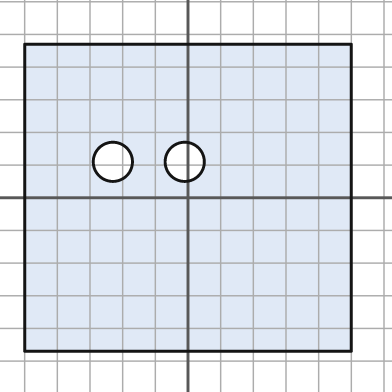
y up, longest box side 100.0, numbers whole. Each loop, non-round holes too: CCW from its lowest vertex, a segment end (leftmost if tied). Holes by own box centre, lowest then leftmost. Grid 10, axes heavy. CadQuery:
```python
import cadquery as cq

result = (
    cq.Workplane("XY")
    .moveTo(-50.0, -47.0)
    .lineTo(50.0, -47.0)
    .lineTo(50.0, 47.0)
    .lineTo(-50.0, 47.0)
    .close()
    .moveTo(-23.0, 11.0)
    .circle(6.0)
    .moveTo(-1.0, 11.0)
    .circle(6.0)
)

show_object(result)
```